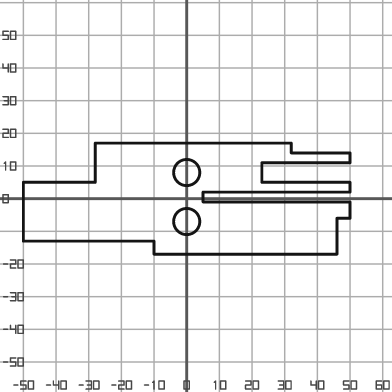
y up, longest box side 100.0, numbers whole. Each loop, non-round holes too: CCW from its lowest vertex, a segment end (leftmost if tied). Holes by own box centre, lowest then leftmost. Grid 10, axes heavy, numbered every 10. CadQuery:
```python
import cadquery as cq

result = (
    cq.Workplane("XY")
    .moveTo(-10.0, -17.0)
    .lineTo(46.0, -17.0)
    .lineTo(46.0, -6.0)
    .lineTo(50.0, -6.0)
    .lineTo(50.0, -1.0)
    .lineTo(5.0, -1.0)
    .lineTo(5.0, 2.0)
    .lineTo(50.0, 2.0)
    .lineTo(50.0, 5.0)
    .lineTo(23.0, 5.0)
    .lineTo(23.0, 11.0)
    .lineTo(50.0, 11.0)
    .lineTo(50.0, 14.0)
    .lineTo(32.0, 14.0)
    .lineTo(32.0, 17.0)
    .lineTo(-28.0, 17.0)
    .lineTo(-28.0, 5.0)
    .lineTo(-50.0, 5.0)
    .lineTo(-50.0, -13.0)
    .lineTo(-10.0, -13.0)
    .close()
    .moveTo(0.0, -7.0)
    .circle(4.0)
    .moveTo(0.0, 8.0)
    .circle(4.0)
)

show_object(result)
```